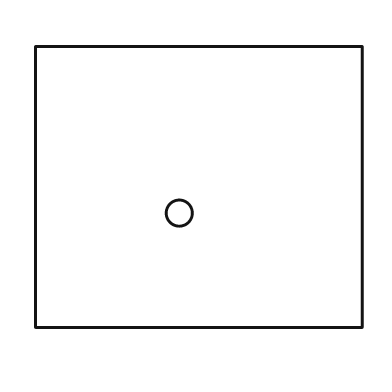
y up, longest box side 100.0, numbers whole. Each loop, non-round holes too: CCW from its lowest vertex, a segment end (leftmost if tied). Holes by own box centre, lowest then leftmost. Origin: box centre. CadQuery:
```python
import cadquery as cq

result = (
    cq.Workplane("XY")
    .moveTo(-50.0, -43.0)
    .lineTo(50.0, -43.0)
    .lineTo(50.0, 43.0)
    .lineTo(-50.0, 43.0)
    .close()
    .moveTo(-6.0, -8.0)
    .circle(4.0)
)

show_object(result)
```